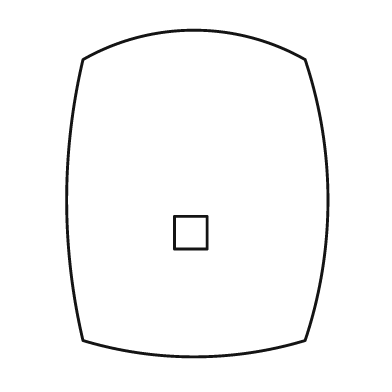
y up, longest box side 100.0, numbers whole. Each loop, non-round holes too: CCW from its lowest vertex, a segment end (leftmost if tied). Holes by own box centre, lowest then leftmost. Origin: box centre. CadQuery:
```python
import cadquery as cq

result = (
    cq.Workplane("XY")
    .moveTo(-35.0, -45.0)
    .threePointArc((-1.0, -50.0), (33.0, -45.0))
    .threePointArc((40.0, -2.0), (33.0, 41.0))
    .threePointArc((-1.0, 50.0), (-35.0, 41.0))
    .threePointArc((-40.0, -2.0), (-35.0, -45.0))
    .close()
    .moveTo(-7.0, -17.0)
    .lineTo(3.0, -17.0)
    .lineTo(3.0, -7.0)
    .lineTo(-7.0, -7.0)
    .close()
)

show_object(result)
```